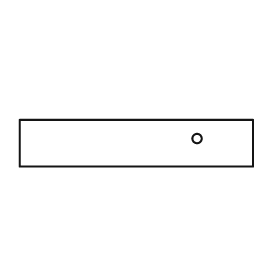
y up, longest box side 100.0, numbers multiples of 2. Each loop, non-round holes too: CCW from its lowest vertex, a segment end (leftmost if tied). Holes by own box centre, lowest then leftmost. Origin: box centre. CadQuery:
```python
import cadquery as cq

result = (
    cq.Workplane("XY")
    .moveTo(-50.0, -10.0)
    .lineTo(50.0, -10.0)
    .lineTo(50.0, 10.0)
    .lineTo(-50.0, 10.0)
    .close()
    .moveTo(26.0, 2.0)
    .circle(2.0)
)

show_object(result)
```